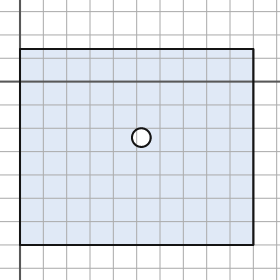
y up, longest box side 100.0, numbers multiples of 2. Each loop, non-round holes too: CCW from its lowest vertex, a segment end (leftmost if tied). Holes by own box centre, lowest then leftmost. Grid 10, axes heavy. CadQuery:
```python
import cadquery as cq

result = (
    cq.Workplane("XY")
    .moveTo(0.0, -70.0)
    .lineTo(100.0, -70.0)
    .lineTo(100.0, 14.0)
    .lineTo(0.0, 14.0)
    .close()
    .moveTo(52.0, -24.0)
    .circle(4.0)
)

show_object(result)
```